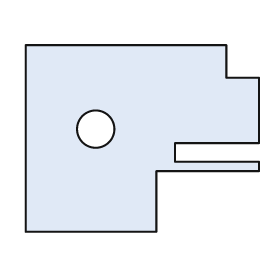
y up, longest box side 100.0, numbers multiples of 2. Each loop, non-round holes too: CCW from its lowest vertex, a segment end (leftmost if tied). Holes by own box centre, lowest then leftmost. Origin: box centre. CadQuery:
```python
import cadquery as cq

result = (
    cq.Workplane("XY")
    .moveTo(-50.0, -40.0)
    .lineTo(6.0, -40.0)
    .lineTo(6.0, -14.0)
    .lineTo(50.0, -14.0)
    .lineTo(50.0, -10.0)
    .lineTo(14.0, -10.0)
    .lineTo(14.0, -2.0)
    .lineTo(50.0, -2.0)
    .lineTo(50.0, 26.0)
    .lineTo(36.0, 26.0)
    .lineTo(36.0, 40.0)
    .lineTo(-50.0, 40.0)
    .close()
    .moveTo(-20.0, 4.0)
    .circle(8.0)
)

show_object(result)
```